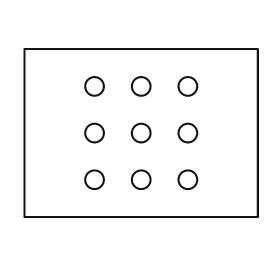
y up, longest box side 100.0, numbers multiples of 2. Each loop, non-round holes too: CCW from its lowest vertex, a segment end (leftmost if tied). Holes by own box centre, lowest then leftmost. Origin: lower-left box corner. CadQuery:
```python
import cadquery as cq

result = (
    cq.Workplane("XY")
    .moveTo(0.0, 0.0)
    .lineTo(100.0, 0.0)
    .lineTo(100.0, 72.0)
    .lineTo(0.0, 72.0)
    .close()
    .moveTo(30.0, 16.0)
    .circle(4.0)
    .moveTo(50.0, 16.0)
    .circle(4.0)
    .moveTo(70.0, 16.0)
    .circle(4.0)
    .moveTo(30.0, 36.0)
    .circle(4.0)
    .moveTo(50.0, 36.0)
    .circle(4.0)
    .moveTo(70.0, 36.0)
    .circle(4.0)
    .moveTo(30.0, 56.0)
    .circle(4.0)
    .moveTo(50.0, 56.0)
    .circle(4.0)
    .moveTo(70.0, 56.0)
    .circle(4.0)
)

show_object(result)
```